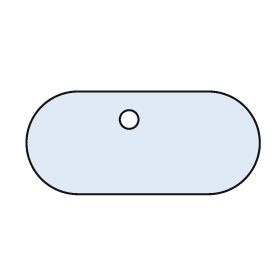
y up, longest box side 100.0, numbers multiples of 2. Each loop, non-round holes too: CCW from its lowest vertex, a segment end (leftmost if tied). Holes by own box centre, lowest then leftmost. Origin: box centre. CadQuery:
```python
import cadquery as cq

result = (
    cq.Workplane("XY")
    .moveTo(-28.0, -22.0)
    .lineTo(28.0, -22.0)
    .threePointArc((50.0, 0.0), (28.0, 22.0))
    .lineTo(-28.0, 22.0)
    .threePointArc((-50.0, 0.0), (-28.0, -22.0))
    .close()
    .moveTo(-6.0, 10.0)
    .circle(4.0)
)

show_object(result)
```